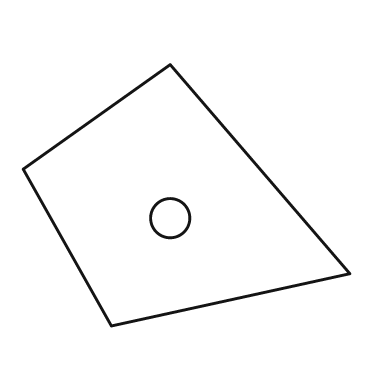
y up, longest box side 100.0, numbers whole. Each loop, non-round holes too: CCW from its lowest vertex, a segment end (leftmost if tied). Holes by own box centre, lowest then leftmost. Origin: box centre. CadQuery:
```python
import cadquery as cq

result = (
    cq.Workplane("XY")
    .moveTo(-23.0, -40.0)
    .lineTo(50.0, -24.0)
    .lineTo(-5.0, 40.0)
    .lineTo(-50.0, 8.0)
    .close()
    .moveTo(-5.0, -7.0)
    .circle(6.0)
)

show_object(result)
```